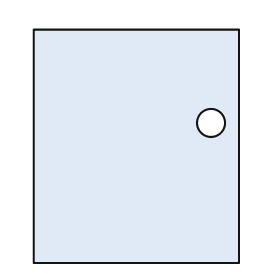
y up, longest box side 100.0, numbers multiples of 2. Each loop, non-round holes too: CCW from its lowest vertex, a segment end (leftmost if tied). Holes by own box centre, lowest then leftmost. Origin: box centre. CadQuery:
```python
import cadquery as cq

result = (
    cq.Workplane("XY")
    .moveTo(-44.0, -50.0)
    .lineTo(44.0, -50.0)
    .lineTo(44.0, 50.0)
    .lineTo(-44.0, 50.0)
    .close()
    .moveTo(32.0, 10.0)
    .circle(6.0)
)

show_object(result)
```